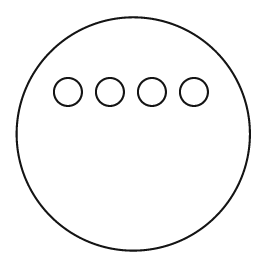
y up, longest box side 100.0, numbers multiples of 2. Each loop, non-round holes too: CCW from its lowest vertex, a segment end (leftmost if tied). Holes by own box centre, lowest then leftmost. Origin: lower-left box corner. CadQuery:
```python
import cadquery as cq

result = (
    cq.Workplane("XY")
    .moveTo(50.0, 50.0)
    .circle(50.0)
    .moveTo(22.0, 68.0)
    .circle(6.0)
    .moveTo(40.0, 68.0)
    .circle(6.0)
    .moveTo(58.0, 68.0)
    .circle(6.0)
    .moveTo(76.0, 68.0)
    .circle(6.0)
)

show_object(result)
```